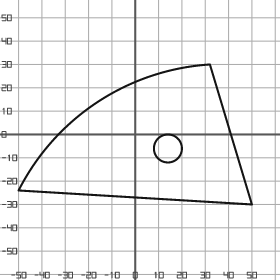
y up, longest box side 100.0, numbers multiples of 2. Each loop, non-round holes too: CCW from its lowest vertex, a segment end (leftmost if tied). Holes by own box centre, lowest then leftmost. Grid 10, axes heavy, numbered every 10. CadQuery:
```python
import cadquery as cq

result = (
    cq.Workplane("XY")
    .moveTo(50.0, -30.0)
    .lineTo(32.0, 30.0)
    .threePointArc((-16.0, 14.0), (-50.0, -24.0))
    .close()
    .moveTo(14.0, -6.0)
    .circle(6.0)
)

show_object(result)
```